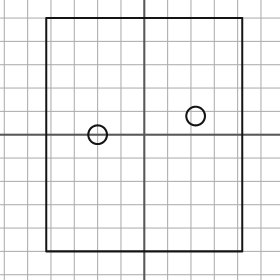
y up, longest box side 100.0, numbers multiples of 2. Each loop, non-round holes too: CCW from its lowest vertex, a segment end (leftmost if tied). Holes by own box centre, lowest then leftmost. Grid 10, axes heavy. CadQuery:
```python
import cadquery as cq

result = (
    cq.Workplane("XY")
    .moveTo(-42.0, -50.0)
    .lineTo(42.0, -50.0)
    .lineTo(42.0, 50.0)
    .lineTo(-42.0, 50.0)
    .close()
    .moveTo(-20.0, 0.0)
    .circle(4.0)
    .moveTo(22.0, 8.0)
    .circle(4.0)
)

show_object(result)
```